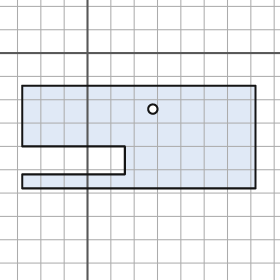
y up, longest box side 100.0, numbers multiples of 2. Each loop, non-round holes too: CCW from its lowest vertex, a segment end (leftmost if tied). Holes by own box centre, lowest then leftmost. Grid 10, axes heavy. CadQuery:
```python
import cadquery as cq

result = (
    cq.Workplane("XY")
    .moveTo(-28.0, -58.0)
    .lineTo(72.0, -58.0)
    .lineTo(72.0, -14.0)
    .lineTo(-28.0, -14.0)
    .lineTo(-28.0, -40.0)
    .lineTo(16.0, -40.0)
    .lineTo(16.0, -52.0)
    .lineTo(-28.0, -52.0)
    .close()
    .moveTo(28.0, -24.0)
    .circle(2.0)
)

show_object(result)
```